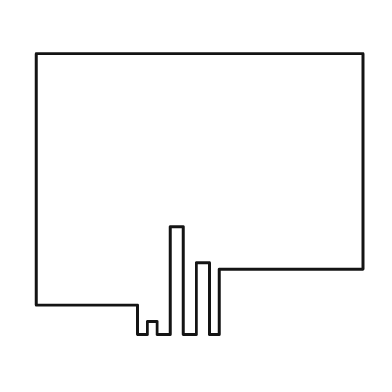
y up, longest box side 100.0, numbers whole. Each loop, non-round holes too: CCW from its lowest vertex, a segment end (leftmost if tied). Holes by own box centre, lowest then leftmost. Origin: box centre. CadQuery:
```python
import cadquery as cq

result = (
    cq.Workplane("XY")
    .moveTo(-19.0, -43.0)
    .lineTo(-16.0, -43.0)
    .lineTo(-16.0, -39.0)
    .lineTo(-13.0, -39.0)
    .lineTo(-13.0, -43.0)
    .lineTo(-9.0, -43.0)
    .lineTo(-9.0, -10.0)
    .lineTo(-5.0, -10.0)
    .lineTo(-5.0, -43.0)
    .lineTo(-1.0, -43.0)
    .lineTo(-1.0, -21.0)
    .lineTo(3.0, -21.0)
    .lineTo(3.0, -43.0)
    .lineTo(6.0, -43.0)
    .lineTo(6.0, -23.0)
    .lineTo(50.0, -23.0)
    .lineTo(50.0, 43.0)
    .lineTo(-50.0, 43.0)
    .lineTo(-50.0, -34.0)
    .lineTo(-19.0, -34.0)
    .close()
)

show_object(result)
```